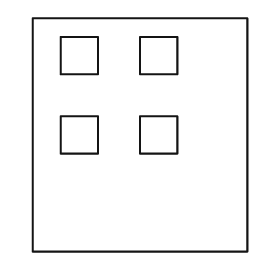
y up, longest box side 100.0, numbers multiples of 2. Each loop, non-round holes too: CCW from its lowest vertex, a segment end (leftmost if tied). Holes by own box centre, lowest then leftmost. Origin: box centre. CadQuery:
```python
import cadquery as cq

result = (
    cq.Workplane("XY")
    .moveTo(-46.0, -50.0)
    .lineTo(46.0, -50.0)
    .lineTo(46.0, 50.0)
    .lineTo(-46.0, 50.0)
    .close()
    .moveTo(-34.0, -8.0)
    .lineTo(-18.0, -8.0)
    .lineTo(-18.0, 8.0)
    .lineTo(-34.0, 8.0)
    .close()
    .moveTo(0.0, -8.0)
    .lineTo(16.0, -8.0)
    .lineTo(16.0, 8.0)
    .lineTo(0.0, 8.0)
    .close()
    .moveTo(-34.0, 26.0)
    .lineTo(-18.0, 26.0)
    .lineTo(-18.0, 42.0)
    .lineTo(-34.0, 42.0)
    .close()
    .moveTo(0.0, 26.0)
    .lineTo(16.0, 26.0)
    .lineTo(16.0, 42.0)
    .lineTo(0.0, 42.0)
    .close()
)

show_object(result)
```